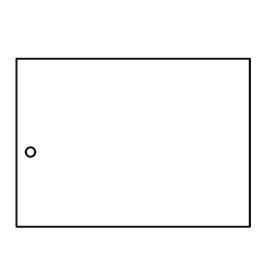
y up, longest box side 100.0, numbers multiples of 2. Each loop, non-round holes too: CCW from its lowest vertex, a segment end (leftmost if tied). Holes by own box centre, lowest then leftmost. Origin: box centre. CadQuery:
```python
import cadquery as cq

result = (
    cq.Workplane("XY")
    .moveTo(-50.0, -36.0)
    .lineTo(50.0, -36.0)
    .lineTo(50.0, 36.0)
    .lineTo(-50.0, 36.0)
    .close()
    .moveTo(-44.0, -4.0)
    .circle(2.0)
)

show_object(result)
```